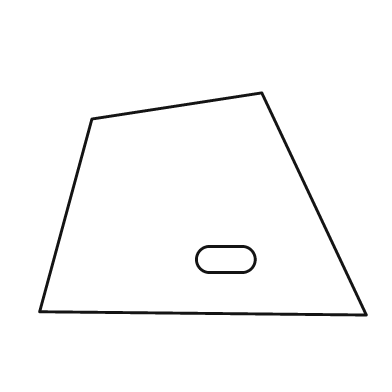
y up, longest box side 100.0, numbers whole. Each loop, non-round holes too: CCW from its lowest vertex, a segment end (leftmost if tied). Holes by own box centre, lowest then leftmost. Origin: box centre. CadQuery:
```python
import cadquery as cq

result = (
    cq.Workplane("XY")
    .moveTo(50.0, -34.0)
    .lineTo(18.0, 34.0)
    .lineTo(-34.0, 26.0)
    .lineTo(-50.0, -33.0)
    .close()
    .moveTo(2.0, -21.0)
    .lineTo(12.0, -21.0)
    .threePointArc((16.0, -17.0), (12.0, -13.0))
    .lineTo(2.0, -13.0)
    .threePointArc((-2.0, -17.0), (2.0, -21.0))
    .close()
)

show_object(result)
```